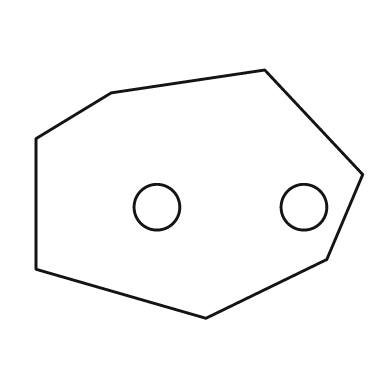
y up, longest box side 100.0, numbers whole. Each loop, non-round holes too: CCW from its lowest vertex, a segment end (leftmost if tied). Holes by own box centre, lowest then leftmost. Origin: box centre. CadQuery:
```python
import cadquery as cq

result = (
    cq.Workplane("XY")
    .moveTo(2.0, -38.0)
    .lineTo(39.0, -20.0)
    .lineTo(50.0, 6.0)
    .lineTo(20.0, 38.0)
    .lineTo(-27.0, 31.0)
    .lineTo(-50.0, 17.0)
    .lineTo(-50.0, -23.0)
    .close()
    .moveTo(-13.0, -4.0)
    .circle(7.0)
    .moveTo(32.0, -4.0)
    .circle(7.0)
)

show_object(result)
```